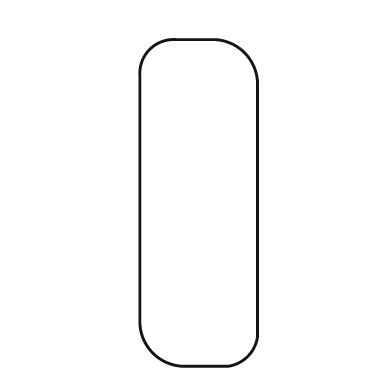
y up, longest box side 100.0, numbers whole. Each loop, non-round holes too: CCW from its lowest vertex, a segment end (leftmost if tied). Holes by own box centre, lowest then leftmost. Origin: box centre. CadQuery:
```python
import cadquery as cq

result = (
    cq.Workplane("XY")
    .moveTo(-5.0, -50.0)
    .lineTo(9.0, -50.0)
    .threePointArc((15.0, -47.0), (18.0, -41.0))
    .lineTo(18.0, 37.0)
    .threePointArc((14.0, 46.0), (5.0, 50.0))
    .lineTo(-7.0, 50.0)
    .threePointArc((-15.0, 47.0), (-18.0, 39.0))
    .lineTo(-18.0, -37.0)
    .threePointArc((-14.0, -46.0), (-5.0, -50.0))
    .close()
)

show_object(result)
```